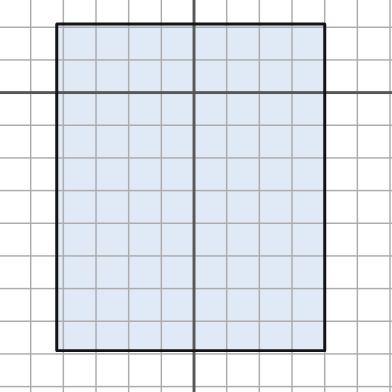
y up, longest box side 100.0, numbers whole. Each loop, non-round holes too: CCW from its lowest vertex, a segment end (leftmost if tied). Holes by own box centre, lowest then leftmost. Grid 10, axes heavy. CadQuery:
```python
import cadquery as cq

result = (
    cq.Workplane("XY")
    .moveTo(-42.0, -79.0)
    .lineTo(40.0, -79.0)
    .lineTo(40.0, 21.0)
    .lineTo(-42.0, 21.0)
    .close()
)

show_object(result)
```